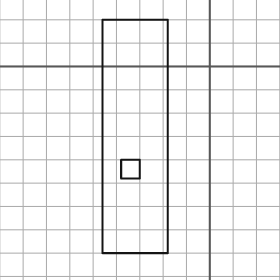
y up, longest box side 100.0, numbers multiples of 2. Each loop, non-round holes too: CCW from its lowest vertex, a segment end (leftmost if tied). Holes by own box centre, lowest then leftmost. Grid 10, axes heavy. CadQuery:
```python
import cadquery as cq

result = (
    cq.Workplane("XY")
    .moveTo(-46.0, -80.0)
    .lineTo(-18.0, -80.0)
    .lineTo(-18.0, 20.0)
    .lineTo(-46.0, 20.0)
    .close()
    .moveTo(-38.0, -48.0)
    .lineTo(-30.0, -48.0)
    .lineTo(-30.0, -40.0)
    .lineTo(-38.0, -40.0)
    .close()
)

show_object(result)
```